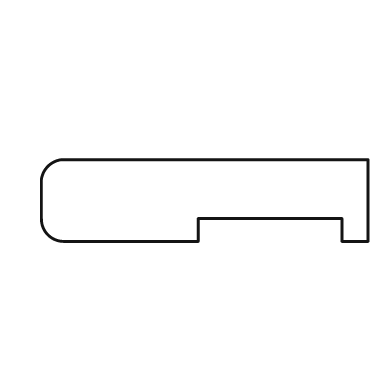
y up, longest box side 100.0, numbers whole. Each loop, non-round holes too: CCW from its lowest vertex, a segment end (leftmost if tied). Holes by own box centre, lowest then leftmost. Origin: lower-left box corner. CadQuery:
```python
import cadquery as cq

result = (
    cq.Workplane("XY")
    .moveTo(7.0, 0.0)
    .lineTo(48.0, 0.0)
    .lineTo(48.0, 7.0)
    .lineTo(92.0, 7.0)
    .lineTo(92.0, 0.0)
    .lineTo(100.0, 0.0)
    .lineTo(100.0, 25.0)
    .lineTo(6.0, 25.0)
    .threePointArc((2.0, 23.0), (0.0, 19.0))
    .lineTo(0.0, 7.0)
    .threePointArc((2.0, 2.0), (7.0, 0.0))
    .close()
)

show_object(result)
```